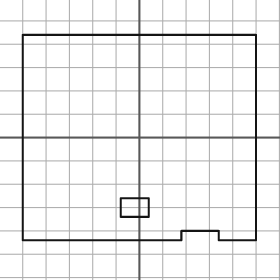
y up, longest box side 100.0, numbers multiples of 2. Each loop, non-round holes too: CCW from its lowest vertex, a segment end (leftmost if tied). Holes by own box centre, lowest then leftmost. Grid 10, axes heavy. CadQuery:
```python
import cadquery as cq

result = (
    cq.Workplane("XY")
    .moveTo(-50.0, -44.0)
    .lineTo(18.0, -44.0)
    .lineTo(18.0, -40.0)
    .lineTo(34.0, -40.0)
    .lineTo(34.0, -44.0)
    .lineTo(50.0, -44.0)
    .lineTo(50.0, 44.0)
    .lineTo(-50.0, 44.0)
    .close()
    .moveTo(-8.0, -34.0)
    .lineTo(4.0, -34.0)
    .lineTo(4.0, -26.0)
    .lineTo(-8.0, -26.0)
    .close()
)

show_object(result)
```